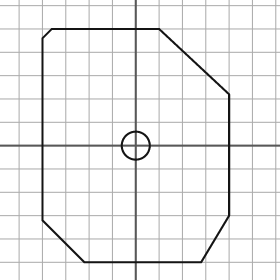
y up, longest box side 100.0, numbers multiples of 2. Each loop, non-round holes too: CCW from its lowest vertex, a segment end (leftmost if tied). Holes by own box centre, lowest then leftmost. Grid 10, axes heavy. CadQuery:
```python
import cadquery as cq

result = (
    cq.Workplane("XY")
    .moveTo(-22.0, -50.0)
    .lineTo(28.0, -50.0)
    .lineTo(40.0, -30.0)
    .lineTo(40.0, 22.0)
    .lineTo(10.0, 50.0)
    .lineTo(-36.0, 50.0)
    .lineTo(-40.0, 46.0)
    .lineTo(-40.0, -32.0)
    .close()
    .moveTo(0.0, 0.0)
    .circle(6.0)
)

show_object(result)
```